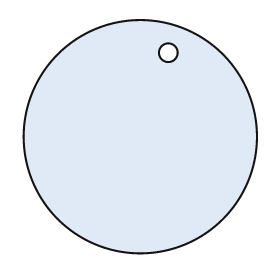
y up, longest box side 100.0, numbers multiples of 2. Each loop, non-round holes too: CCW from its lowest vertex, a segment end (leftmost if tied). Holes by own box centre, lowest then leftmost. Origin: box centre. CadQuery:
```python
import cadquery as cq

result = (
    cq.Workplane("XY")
    .moveTo(0.0, 0.0)
    .circle(50.0)
    .moveTo(12.0, 36.0)
    .circle(4.0)
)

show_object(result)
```